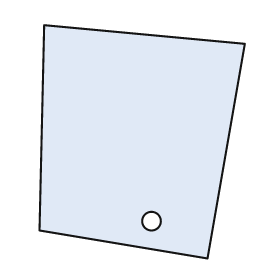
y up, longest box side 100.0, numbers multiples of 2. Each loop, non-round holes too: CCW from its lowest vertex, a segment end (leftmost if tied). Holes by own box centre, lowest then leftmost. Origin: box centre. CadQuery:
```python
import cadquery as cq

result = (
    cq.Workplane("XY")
    .moveTo(28.0, -50.0)
    .lineTo(44.0, 42.0)
    .lineTo(-42.0, 50.0)
    .lineTo(-44.0, -38.0)
    .close()
    .moveTo(4.0, -34.0)
    .circle(4.0)
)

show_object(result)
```